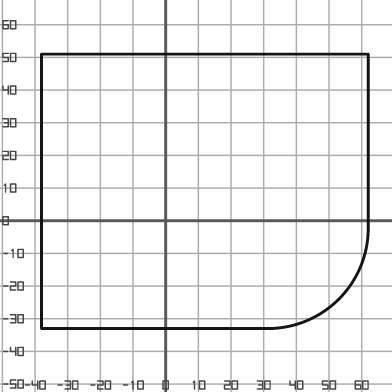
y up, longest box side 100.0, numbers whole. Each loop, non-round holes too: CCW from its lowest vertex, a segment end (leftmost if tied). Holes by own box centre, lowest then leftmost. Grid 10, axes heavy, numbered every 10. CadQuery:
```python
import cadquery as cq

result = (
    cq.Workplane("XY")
    .moveTo(-38.0, -33.0)
    .lineTo(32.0, -33.0)
    .threePointArc((53.0, -24.0), (62.0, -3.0))
    .lineTo(62.0, 51.0)
    .lineTo(-38.0, 51.0)
    .close()
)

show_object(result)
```